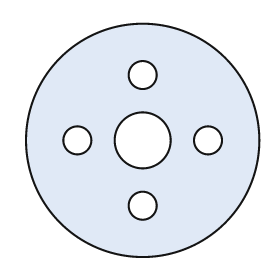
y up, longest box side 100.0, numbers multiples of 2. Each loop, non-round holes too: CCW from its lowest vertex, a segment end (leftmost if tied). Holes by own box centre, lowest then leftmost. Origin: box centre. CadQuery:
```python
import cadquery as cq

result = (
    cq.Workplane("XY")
    .moveTo(0.0, 0.0)
    .circle(50.0)
    .moveTo(0.0, -28.0)
    .circle(6.0)
    .moveTo(-28.0, 0.0)
    .circle(6.0)
    .moveTo(0.0, 0.0)
    .circle(12.0)
    .moveTo(28.0, 0.0)
    .circle(6.0)
    .moveTo(0.0, 28.0)
    .circle(6.0)
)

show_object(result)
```